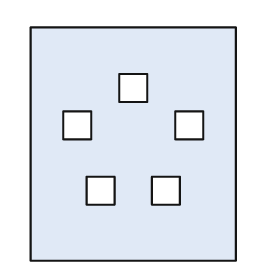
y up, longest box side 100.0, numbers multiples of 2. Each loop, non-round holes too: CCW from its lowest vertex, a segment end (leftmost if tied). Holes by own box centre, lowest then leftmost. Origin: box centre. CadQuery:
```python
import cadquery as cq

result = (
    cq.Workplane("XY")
    .moveTo(-44.0, -50.0)
    .lineTo(44.0, -50.0)
    .lineTo(44.0, 50.0)
    .lineTo(-44.0, 50.0)
    .close()
    .moveTo(-20.0, -26.0)
    .lineTo(-8.0, -26.0)
    .lineTo(-8.0, -14.0)
    .lineTo(-20.0, -14.0)
    .close()
    .moveTo(8.0, -26.0)
    .lineTo(20.0, -26.0)
    .lineTo(20.0, -14.0)
    .lineTo(8.0, -14.0)
    .close()
    .moveTo(-30.0, 2.0)
    .lineTo(-18.0, 2.0)
    .lineTo(-18.0, 14.0)
    .lineTo(-30.0, 14.0)
    .close()
    .moveTo(18.0, 2.0)
    .lineTo(30.0, 2.0)
    .lineTo(30.0, 14.0)
    .lineTo(18.0, 14.0)
    .close()
    .moveTo(-6.0, 18.0)
    .lineTo(6.0, 18.0)
    .lineTo(6.0, 30.0)
    .lineTo(-6.0, 30.0)
    .close()
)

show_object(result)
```